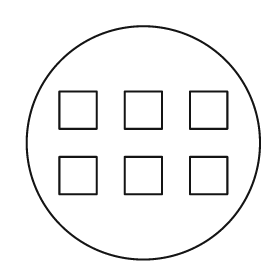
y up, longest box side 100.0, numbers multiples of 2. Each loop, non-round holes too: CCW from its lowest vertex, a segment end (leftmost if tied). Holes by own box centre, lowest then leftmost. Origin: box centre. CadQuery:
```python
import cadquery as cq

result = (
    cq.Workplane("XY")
    .moveTo(0.0, 0.0)
    .circle(50.0)
    .moveTo(-36.0, -22.0)
    .lineTo(-20.0, -22.0)
    .lineTo(-20.0, -6.0)
    .lineTo(-36.0, -6.0)
    .close()
    .moveTo(-8.0, -22.0)
    .lineTo(8.0, -22.0)
    .lineTo(8.0, -6.0)
    .lineTo(-8.0, -6.0)
    .close()
    .moveTo(20.0, -22.0)
    .lineTo(36.0, -22.0)
    .lineTo(36.0, -6.0)
    .lineTo(20.0, -6.0)
    .close()
    .moveTo(-36.0, 6.0)
    .lineTo(-20.0, 6.0)
    .lineTo(-20.0, 22.0)
    .lineTo(-36.0, 22.0)
    .close()
    .moveTo(-8.0, 6.0)
    .lineTo(8.0, 6.0)
    .lineTo(8.0, 22.0)
    .lineTo(-8.0, 22.0)
    .close()
    .moveTo(20.0, 6.0)
    .lineTo(36.0, 6.0)
    .lineTo(36.0, 22.0)
    .lineTo(20.0, 22.0)
    .close()
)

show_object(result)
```